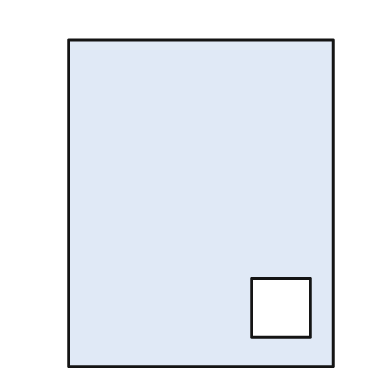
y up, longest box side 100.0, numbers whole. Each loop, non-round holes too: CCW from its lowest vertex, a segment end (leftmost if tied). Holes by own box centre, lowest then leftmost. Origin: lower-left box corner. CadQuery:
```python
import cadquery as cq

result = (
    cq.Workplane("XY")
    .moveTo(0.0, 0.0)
    .lineTo(81.0, 0.0)
    .lineTo(81.0, 100.0)
    .lineTo(0.0, 100.0)
    .close()
    .moveTo(56.0, 9.0)
    .lineTo(74.0, 9.0)
    .lineTo(74.0, 27.0)
    .lineTo(56.0, 27.0)
    .close()
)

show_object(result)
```